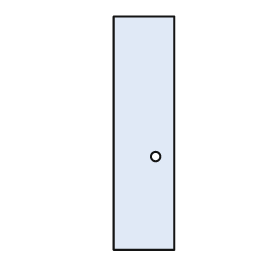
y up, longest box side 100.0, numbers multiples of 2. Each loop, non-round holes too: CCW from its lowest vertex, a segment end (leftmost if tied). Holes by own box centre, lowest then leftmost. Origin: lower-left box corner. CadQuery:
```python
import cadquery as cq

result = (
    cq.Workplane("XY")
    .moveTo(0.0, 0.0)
    .lineTo(26.0, 0.0)
    .lineTo(26.0, 100.0)
    .lineTo(0.0, 100.0)
    .close()
    .moveTo(18.0, 40.0)
    .circle(2.0)
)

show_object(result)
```